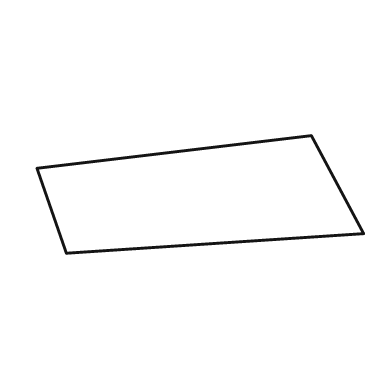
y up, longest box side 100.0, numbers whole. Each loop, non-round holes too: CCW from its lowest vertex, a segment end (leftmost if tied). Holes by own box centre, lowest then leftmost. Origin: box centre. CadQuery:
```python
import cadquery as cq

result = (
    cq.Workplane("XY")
    .moveTo(-41.0, -18.0)
    .lineTo(50.0, -12.0)
    .lineTo(34.0, 18.0)
    .lineTo(-50.0, 8.0)
    .close()
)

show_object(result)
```